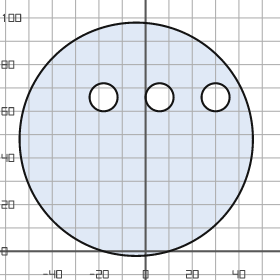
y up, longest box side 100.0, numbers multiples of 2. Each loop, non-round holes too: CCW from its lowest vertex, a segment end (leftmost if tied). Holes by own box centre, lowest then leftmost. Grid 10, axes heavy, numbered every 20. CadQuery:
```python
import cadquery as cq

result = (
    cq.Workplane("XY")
    .moveTo(-4.0, 48.0)
    .circle(50.0)
    .moveTo(-18.0, 66.0)
    .circle(6.0)
    .moveTo(6.0, 66.0)
    .circle(6.0)
    .moveTo(30.0, 66.0)
    .circle(6.0)
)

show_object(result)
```